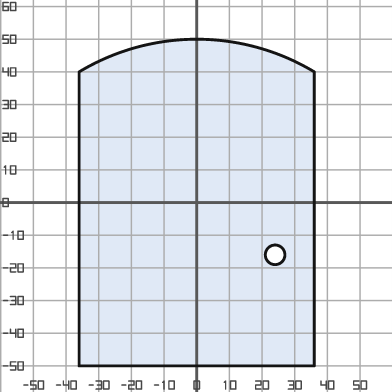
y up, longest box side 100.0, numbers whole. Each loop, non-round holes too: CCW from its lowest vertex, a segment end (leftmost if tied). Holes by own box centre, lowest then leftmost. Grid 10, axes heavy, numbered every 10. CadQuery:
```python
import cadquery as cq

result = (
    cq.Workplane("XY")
    .moveTo(-36.0, -50.0)
    .lineTo(36.0, -50.0)
    .lineTo(36.0, 40.0)
    .threePointArc((0.0, 50.0), (-36.0, 40.0))
    .close()
    .moveTo(24.0, -16.0)
    .circle(3.0)
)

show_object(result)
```